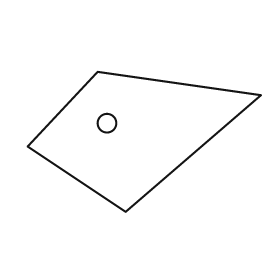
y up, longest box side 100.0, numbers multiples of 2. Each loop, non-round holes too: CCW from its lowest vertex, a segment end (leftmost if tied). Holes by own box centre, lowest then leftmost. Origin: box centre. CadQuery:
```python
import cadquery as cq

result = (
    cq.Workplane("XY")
    .moveTo(-8.0, -30.0)
    .lineTo(50.0, 20.0)
    .lineTo(-20.0, 30.0)
    .lineTo(-50.0, -2.0)
    .close()
    .moveTo(-16.0, 8.0)
    .circle(4.0)
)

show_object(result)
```